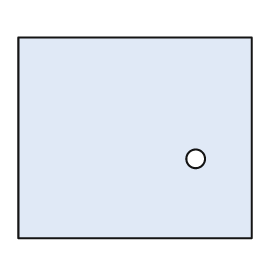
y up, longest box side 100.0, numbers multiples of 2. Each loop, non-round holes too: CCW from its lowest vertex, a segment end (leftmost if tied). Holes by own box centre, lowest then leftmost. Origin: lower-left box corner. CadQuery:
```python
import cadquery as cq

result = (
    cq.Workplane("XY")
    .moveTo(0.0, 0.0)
    .lineTo(100.0, 0.0)
    .lineTo(100.0, 86.0)
    .lineTo(0.0, 86.0)
    .close()
    .moveTo(76.0, 34.0)
    .circle(4.0)
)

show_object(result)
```